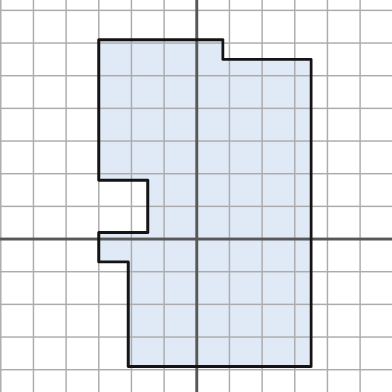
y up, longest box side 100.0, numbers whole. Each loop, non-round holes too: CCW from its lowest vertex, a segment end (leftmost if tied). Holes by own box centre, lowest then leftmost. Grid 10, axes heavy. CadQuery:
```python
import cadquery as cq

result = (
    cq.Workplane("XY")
    .moveTo(-21.0, -39.0)
    .lineTo(35.0, -39.0)
    .lineTo(35.0, 55.0)
    .lineTo(8.0, 55.0)
    .lineTo(8.0, 61.0)
    .lineTo(-30.0, 61.0)
    .lineTo(-30.0, 18.0)
    .lineTo(-15.0, 18.0)
    .lineTo(-15.0, 2.0)
    .lineTo(-30.0, 2.0)
    .lineTo(-30.0, -7.0)
    .lineTo(-21.0, -7.0)
    .close()
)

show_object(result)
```